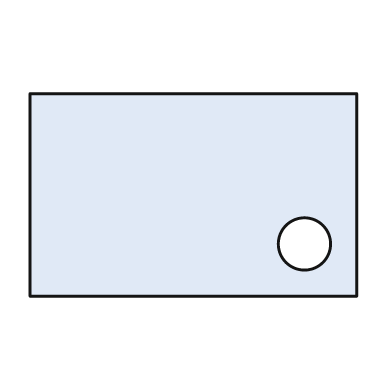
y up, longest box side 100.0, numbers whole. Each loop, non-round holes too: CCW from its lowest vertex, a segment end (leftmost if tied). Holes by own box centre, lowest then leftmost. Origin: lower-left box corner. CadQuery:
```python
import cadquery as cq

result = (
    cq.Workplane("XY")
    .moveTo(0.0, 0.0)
    .lineTo(100.0, 0.0)
    .lineTo(100.0, 62.0)
    .lineTo(0.0, 62.0)
    .close()
    .moveTo(84.0, 16.0)
    .circle(8.0)
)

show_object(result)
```